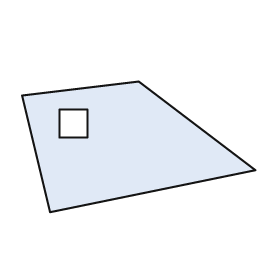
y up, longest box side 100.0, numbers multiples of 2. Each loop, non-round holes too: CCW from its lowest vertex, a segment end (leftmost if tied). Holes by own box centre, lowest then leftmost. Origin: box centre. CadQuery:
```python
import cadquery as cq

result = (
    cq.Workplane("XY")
    .moveTo(-38.0, -28.0)
    .lineTo(50.0, -10.0)
    .lineTo(0.0, 28.0)
    .lineTo(-50.0, 22.0)
    .close()
    .moveTo(-34.0, 4.0)
    .lineTo(-22.0, 4.0)
    .lineTo(-22.0, 16.0)
    .lineTo(-34.0, 16.0)
    .close()
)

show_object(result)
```